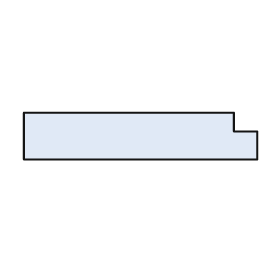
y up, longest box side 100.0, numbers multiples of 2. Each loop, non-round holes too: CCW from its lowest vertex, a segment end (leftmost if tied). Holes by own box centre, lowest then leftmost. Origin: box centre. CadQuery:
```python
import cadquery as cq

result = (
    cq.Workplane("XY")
    .moveTo(-50.0, -10.0)
    .lineTo(50.0, -10.0)
    .lineTo(50.0, 2.0)
    .lineTo(40.0, 2.0)
    .lineTo(40.0, 10.0)
    .lineTo(-50.0, 10.0)
    .close()
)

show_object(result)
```